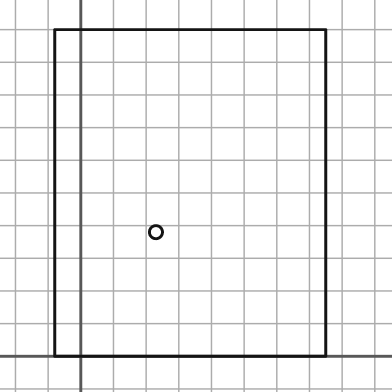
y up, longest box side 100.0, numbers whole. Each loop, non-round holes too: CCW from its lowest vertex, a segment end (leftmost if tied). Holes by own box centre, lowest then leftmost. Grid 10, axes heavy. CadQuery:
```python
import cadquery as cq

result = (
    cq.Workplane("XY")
    .moveTo(-8.0, 0.0)
    .lineTo(75.0, 0.0)
    .lineTo(75.0, 100.0)
    .lineTo(-8.0, 100.0)
    .close()
    .moveTo(23.0, 38.0)
    .circle(2.0)
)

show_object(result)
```